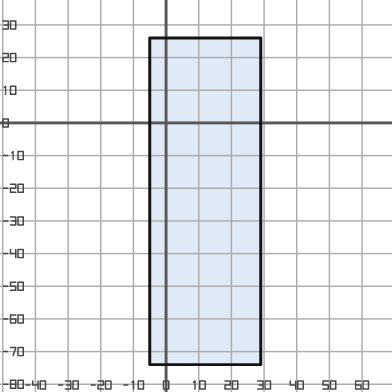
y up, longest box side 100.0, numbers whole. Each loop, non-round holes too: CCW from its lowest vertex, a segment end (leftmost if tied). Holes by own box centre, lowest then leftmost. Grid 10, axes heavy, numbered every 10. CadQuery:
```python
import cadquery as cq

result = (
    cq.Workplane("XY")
    .moveTo(-5.0, -74.0)
    .lineTo(29.0, -74.0)
    .lineTo(29.0, 26.0)
    .lineTo(-5.0, 26.0)
    .close()
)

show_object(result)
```